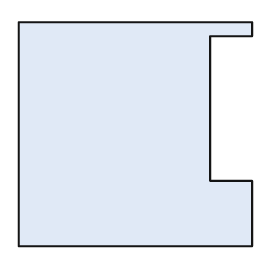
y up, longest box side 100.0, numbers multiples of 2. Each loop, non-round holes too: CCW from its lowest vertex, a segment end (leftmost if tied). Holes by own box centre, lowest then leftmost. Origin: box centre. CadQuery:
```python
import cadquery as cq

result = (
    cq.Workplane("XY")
    .moveTo(-50.0, -48.0)
    .lineTo(50.0, -48.0)
    .lineTo(50.0, -20.0)
    .lineTo(32.0, -20.0)
    .lineTo(32.0, 42.0)
    .lineTo(50.0, 42.0)
    .lineTo(50.0, 48.0)
    .lineTo(-50.0, 48.0)
    .close()
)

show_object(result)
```